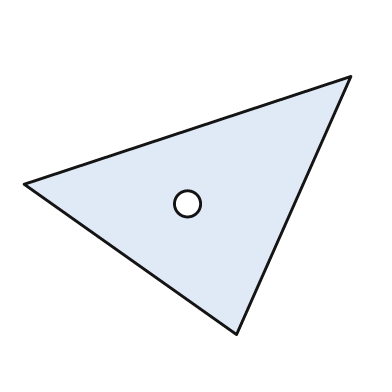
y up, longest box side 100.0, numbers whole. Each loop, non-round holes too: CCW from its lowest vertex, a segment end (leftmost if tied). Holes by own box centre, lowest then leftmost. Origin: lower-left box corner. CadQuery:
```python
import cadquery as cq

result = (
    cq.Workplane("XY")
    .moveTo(65.0, 0.0)
    .lineTo(100.0, 79.0)
    .lineTo(0.0, 46.0)
    .close()
    .moveTo(50.0, 40.0)
    .circle(4.0)
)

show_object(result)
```